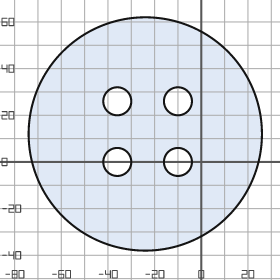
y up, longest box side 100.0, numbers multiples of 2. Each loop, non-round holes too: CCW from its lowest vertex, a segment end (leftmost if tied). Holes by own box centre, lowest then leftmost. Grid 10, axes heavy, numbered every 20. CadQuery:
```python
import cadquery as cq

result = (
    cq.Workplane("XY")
    .moveTo(-24.0, 12.0)
    .circle(50.0)
    .moveTo(-36.0, 0.0)
    .circle(6.0)
    .moveTo(-10.0, 0.0)
    .circle(6.0)
    .moveTo(-36.0, 26.0)
    .circle(6.0)
    .moveTo(-10.0, 26.0)
    .circle(6.0)
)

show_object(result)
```